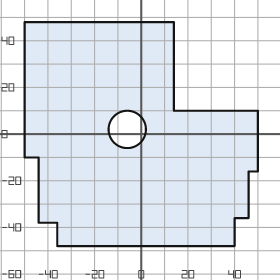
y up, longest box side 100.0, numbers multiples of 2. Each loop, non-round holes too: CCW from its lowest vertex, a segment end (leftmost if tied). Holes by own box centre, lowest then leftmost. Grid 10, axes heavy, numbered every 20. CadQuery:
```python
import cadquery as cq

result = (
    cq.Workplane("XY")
    .moveTo(-36.0, -48.0)
    .lineTo(40.0, -48.0)
    .lineTo(40.0, -36.0)
    .lineTo(46.0, -36.0)
    .lineTo(46.0, -16.0)
    .lineTo(50.0, -16.0)
    .lineTo(50.0, 10.0)
    .lineTo(14.0, 10.0)
    .lineTo(14.0, 48.0)
    .lineTo(-50.0, 48.0)
    .lineTo(-50.0, -10.0)
    .lineTo(-44.0, -10.0)
    .lineTo(-44.0, -38.0)
    .lineTo(-36.0, -38.0)
    .close()
    .moveTo(-6.0, 2.0)
    .circle(8.0)
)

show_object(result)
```